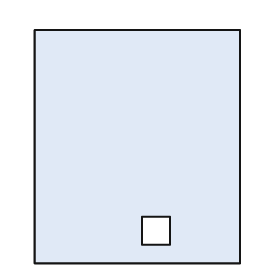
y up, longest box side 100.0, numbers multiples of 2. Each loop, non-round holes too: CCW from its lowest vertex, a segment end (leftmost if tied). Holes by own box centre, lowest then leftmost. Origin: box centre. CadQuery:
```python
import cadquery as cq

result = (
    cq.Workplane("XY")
    .moveTo(-44.0, -50.0)
    .lineTo(44.0, -50.0)
    .lineTo(44.0, 50.0)
    .lineTo(-44.0, 50.0)
    .close()
    .moveTo(2.0, -42.0)
    .lineTo(14.0, -42.0)
    .lineTo(14.0, -30.0)
    .lineTo(2.0, -30.0)
    .close()
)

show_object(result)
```